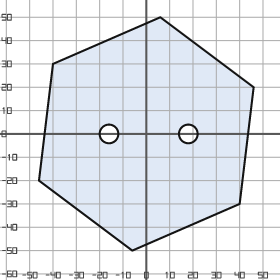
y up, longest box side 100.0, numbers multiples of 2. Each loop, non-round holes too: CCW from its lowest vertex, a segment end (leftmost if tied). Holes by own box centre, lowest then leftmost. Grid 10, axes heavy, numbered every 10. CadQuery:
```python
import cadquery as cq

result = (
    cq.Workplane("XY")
    .moveTo(-6.0, -50.0)
    .lineTo(40.0, -30.0)
    .lineTo(46.0, 20.0)
    .lineTo(6.0, 50.0)
    .lineTo(-40.0, 30.0)
    .lineTo(-46.0, -20.0)
    .close()
    .moveTo(-16.0, 0.0)
    .circle(4.0)
    .moveTo(18.0, 0.0)
    .circle(4.0)
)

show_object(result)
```